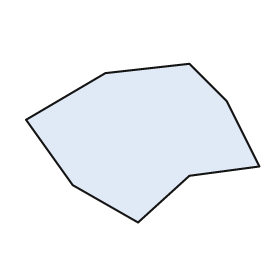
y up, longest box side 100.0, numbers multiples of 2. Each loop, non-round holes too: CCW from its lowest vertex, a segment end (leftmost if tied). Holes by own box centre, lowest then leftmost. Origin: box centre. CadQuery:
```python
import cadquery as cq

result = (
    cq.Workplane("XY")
    .moveTo(-2.0, -34.0)
    .lineTo(20.0, -14.0)
    .lineTo(50.0, -10.0)
    .lineTo(36.0, 18.0)
    .lineTo(20.0, 34.0)
    .lineTo(-16.0, 30.0)
    .lineTo(-50.0, 10.0)
    .lineTo(-30.0, -18.0)
    .close()
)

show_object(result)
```